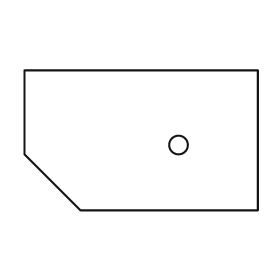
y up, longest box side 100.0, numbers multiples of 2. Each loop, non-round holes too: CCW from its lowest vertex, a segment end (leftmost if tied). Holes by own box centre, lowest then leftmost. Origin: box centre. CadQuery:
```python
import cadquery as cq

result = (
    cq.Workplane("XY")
    .moveTo(-26.0, -30.0)
    .lineTo(50.0, -30.0)
    .lineTo(50.0, 30.0)
    .lineTo(-50.0, 30.0)
    .lineTo(-50.0, -6.0)
    .close()
    .moveTo(16.0, -2.0)
    .circle(4.0)
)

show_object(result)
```